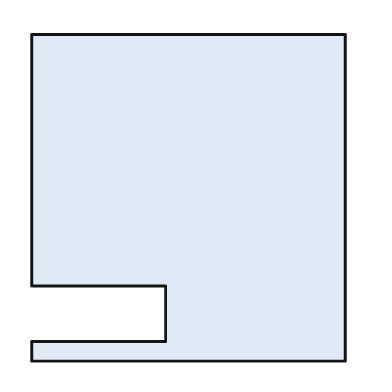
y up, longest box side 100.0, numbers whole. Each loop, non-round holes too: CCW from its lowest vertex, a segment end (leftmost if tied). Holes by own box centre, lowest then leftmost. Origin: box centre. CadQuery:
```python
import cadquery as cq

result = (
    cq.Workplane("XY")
    .moveTo(-48.0, -50.0)
    .lineTo(48.0, -50.0)
    .lineTo(48.0, 50.0)
    .lineTo(-48.0, 50.0)
    .lineTo(-48.0, -27.0)
    .lineTo(-7.0, -27.0)
    .lineTo(-7.0, -44.0)
    .lineTo(-48.0, -44.0)
    .close()
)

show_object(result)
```